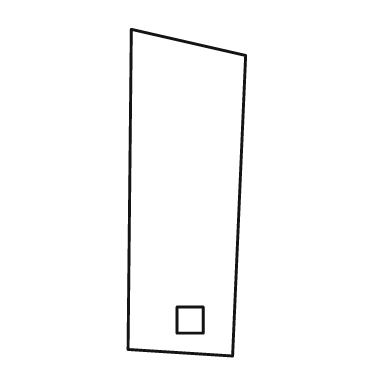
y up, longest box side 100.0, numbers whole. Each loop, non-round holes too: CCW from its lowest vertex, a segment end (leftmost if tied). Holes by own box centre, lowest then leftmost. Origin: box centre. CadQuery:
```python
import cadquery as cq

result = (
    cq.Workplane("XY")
    .moveTo(14.0, -50.0)
    .lineTo(18.0, 42.0)
    .lineTo(-17.0, 50.0)
    .lineTo(-18.0, -48.0)
    .close()
    .moveTo(-3.0, -43.0)
    .lineTo(5.0, -43.0)
    .lineTo(5.0, -35.0)
    .lineTo(-3.0, -35.0)
    .close()
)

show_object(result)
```